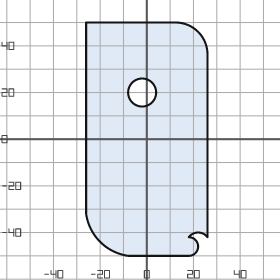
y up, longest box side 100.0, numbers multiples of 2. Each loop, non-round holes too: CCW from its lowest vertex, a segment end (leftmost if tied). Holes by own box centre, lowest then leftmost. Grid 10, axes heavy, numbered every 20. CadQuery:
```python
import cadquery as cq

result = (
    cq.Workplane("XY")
    .moveTo(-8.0, -50.0)
    .lineTo(18.0, -50.0)
    .threePointArc((22.0, -46.0), (18.0, -42.0))
    .threePointArc((22.0, -40.0), (26.0, -42.0))
    .lineTo(26.0, 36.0)
    .threePointArc((22.0, 46.0), (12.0, 50.0))
    .lineTo(-26.0, 50.0)
    .lineTo(-26.0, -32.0)
    .threePointArc((-20.0, -44.0), (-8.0, -50.0))
    .close()
    .moveTo(-2.0, 20.0)
    .circle(6.0)
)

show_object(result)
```